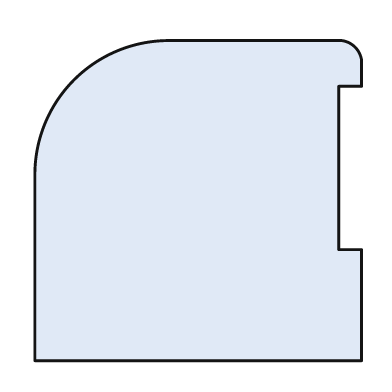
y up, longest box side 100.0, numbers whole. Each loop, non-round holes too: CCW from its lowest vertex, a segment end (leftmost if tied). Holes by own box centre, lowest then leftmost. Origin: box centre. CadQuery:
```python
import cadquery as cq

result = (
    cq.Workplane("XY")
    .moveTo(-50.0, -49.0)
    .lineTo(50.0, -49.0)
    .lineTo(50.0, -15.0)
    .lineTo(43.0, -15.0)
    .lineTo(43.0, 35.0)
    .lineTo(50.0, 35.0)
    .lineTo(50.0, 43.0)
    .threePointArc((48.0, 47.0), (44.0, 49.0))
    .lineTo(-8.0, 49.0)
    .threePointArc((-38.0, 37.0), (-50.0, 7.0))
    .close()
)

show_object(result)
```